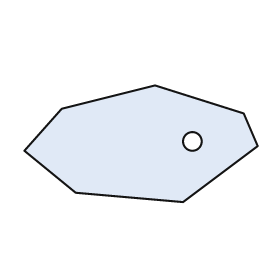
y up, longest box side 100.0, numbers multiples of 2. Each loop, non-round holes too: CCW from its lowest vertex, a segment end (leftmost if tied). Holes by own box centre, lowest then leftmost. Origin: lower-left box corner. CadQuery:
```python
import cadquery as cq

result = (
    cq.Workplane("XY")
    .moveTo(68.0, 0.0)
    .lineTo(100.0, 24.0)
    .lineTo(94.0, 38.0)
    .lineTo(56.0, 50.0)
    .lineTo(16.0, 40.0)
    .lineTo(0.0, 22.0)
    .lineTo(22.0, 4.0)
    .close()
    .moveTo(72.0, 26.0)
    .circle(4.0)
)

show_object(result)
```